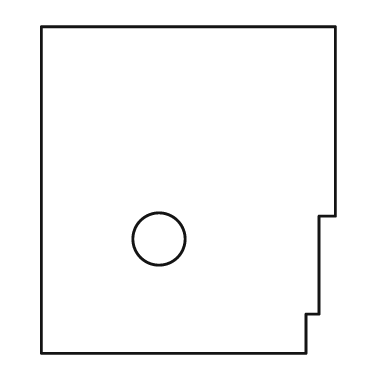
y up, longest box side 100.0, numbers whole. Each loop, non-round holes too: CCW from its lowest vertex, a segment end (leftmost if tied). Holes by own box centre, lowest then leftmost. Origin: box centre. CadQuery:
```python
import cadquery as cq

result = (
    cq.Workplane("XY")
    .moveTo(-45.0, -50.0)
    .lineTo(36.0, -50.0)
    .lineTo(36.0, -38.0)
    .lineTo(40.0, -38.0)
    .lineTo(40.0, -8.0)
    .lineTo(45.0, -8.0)
    .lineTo(45.0, 50.0)
    .lineTo(-45.0, 50.0)
    .close()
    .moveTo(-9.0, -15.0)
    .circle(8.0)
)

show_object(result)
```